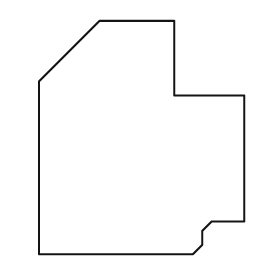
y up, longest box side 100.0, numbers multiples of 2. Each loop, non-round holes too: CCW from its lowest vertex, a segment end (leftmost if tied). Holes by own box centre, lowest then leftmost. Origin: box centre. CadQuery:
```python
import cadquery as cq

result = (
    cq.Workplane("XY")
    .moveTo(-44.0, -50.0)
    .lineTo(22.0, -50.0)
    .lineTo(26.0, -46.0)
    .lineTo(26.0, -40.0)
    .lineTo(30.0, -36.0)
    .lineTo(44.0, -36.0)
    .lineTo(44.0, 18.0)
    .lineTo(14.0, 18.0)
    .lineTo(14.0, 50.0)
    .lineTo(-18.0, 50.0)
    .lineTo(-44.0, 24.0)
    .close()
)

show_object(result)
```